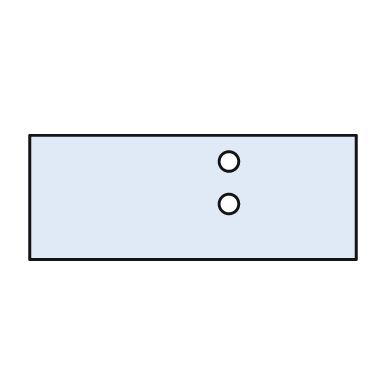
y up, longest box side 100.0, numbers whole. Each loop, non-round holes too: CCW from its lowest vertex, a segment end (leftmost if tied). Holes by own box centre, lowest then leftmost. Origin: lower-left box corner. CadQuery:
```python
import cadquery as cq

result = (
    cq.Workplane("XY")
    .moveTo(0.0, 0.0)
    .lineTo(100.0, 0.0)
    .lineTo(100.0, 38.0)
    .lineTo(0.0, 38.0)
    .close()
    .moveTo(61.0, 17.0)
    .circle(3.0)
    .moveTo(61.0, 30.0)
    .circle(3.0)
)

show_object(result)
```